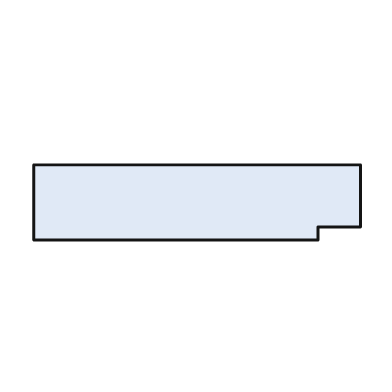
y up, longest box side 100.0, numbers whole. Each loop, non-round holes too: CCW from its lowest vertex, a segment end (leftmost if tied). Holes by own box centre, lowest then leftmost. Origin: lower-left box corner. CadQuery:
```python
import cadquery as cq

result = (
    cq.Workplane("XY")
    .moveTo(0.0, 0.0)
    .lineTo(87.0, 0.0)
    .lineTo(87.0, 4.0)
    .lineTo(100.0, 4.0)
    .lineTo(100.0, 23.0)
    .lineTo(0.0, 23.0)
    .close()
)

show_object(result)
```